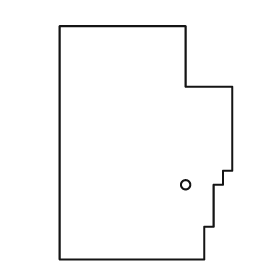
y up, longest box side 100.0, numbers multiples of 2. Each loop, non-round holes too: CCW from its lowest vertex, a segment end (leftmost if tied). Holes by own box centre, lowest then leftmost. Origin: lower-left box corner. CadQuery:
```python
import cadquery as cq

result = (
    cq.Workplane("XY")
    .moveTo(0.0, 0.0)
    .lineTo(62.0, 0.0)
    .lineTo(62.0, 14.0)
    .lineTo(66.0, 14.0)
    .lineTo(66.0, 32.0)
    .lineTo(70.0, 32.0)
    .lineTo(70.0, 38.0)
    .lineTo(74.0, 38.0)
    .lineTo(74.0, 74.0)
    .lineTo(54.0, 74.0)
    .lineTo(54.0, 100.0)
    .lineTo(0.0, 100.0)
    .close()
    .moveTo(54.0, 32.0)
    .circle(2.0)
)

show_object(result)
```